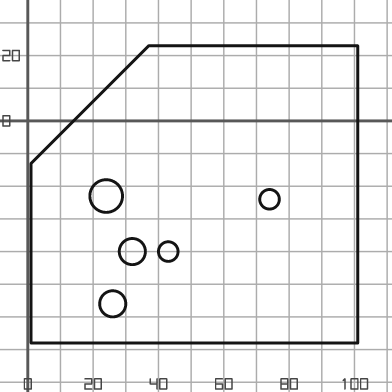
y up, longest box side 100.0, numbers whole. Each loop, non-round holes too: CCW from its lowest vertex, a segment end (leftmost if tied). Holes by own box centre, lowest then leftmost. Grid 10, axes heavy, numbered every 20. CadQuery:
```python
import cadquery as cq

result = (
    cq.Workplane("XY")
    .moveTo(1.0, -68.0)
    .lineTo(101.0, -68.0)
    .lineTo(101.0, 23.0)
    .lineTo(37.0, 23.0)
    .lineTo(1.0, -13.0)
    .close()
    .moveTo(26.0, -56.0)
    .circle(4.0)
    .moveTo(32.0, -40.0)
    .circle(4.0)
    .moveTo(43.0, -40.0)
    .circle(3.0)
    .moveTo(74.0, -24.0)
    .circle(3.0)
    .moveTo(24.0, -23.0)
    .circle(5.0)
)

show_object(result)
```